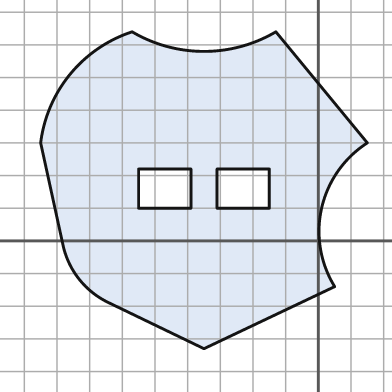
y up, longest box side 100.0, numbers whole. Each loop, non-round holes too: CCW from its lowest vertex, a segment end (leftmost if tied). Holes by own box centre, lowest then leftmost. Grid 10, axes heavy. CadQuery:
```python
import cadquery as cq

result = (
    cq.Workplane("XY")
    .moveTo(-35.0, -33.0)
    .lineTo(5.0, -14.0)
    .threePointArc((1.0, 10.0), (15.0, 30.0))
    .lineTo(-13.0, 64.0)
    .threePointArc((-35.0, 58.0), (-57.0, 64.0))
    .threePointArc((-76.0, 51.0), (-85.0, 30.0))
    .lineTo(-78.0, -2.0)
    .threePointArc((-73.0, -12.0), (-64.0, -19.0))
    .close()
    .moveTo(-55.0, 10.0)
    .lineTo(-39.0, 10.0)
    .lineTo(-39.0, 22.0)
    .lineTo(-55.0, 22.0)
    .close()
    .moveTo(-31.0, 10.0)
    .lineTo(-15.0, 10.0)
    .lineTo(-15.0, 22.0)
    .lineTo(-31.0, 22.0)
    .close()
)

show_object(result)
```